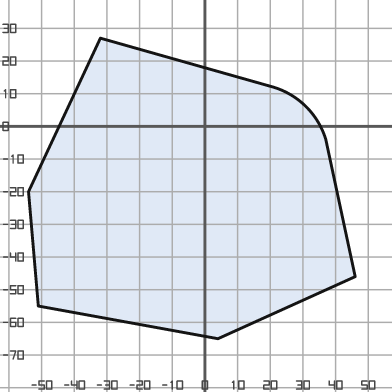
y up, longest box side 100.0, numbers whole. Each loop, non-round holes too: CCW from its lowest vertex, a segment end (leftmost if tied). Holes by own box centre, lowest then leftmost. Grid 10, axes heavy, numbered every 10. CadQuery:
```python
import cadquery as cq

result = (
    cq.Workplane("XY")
    .moveTo(4.0, -65.0)
    .lineTo(46.0, -46.0)
    .lineTo(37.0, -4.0)
    .threePointArc((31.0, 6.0), (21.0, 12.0))
    .lineTo(-32.0, 27.0)
    .lineTo(-54.0, -20.0)
    .lineTo(-51.0, -55.0)
    .close()
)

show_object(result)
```